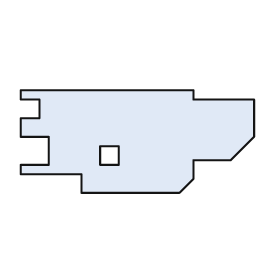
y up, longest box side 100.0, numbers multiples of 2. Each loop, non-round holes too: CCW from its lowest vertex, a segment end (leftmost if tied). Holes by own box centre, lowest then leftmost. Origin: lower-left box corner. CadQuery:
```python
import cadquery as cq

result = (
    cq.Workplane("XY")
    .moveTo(26.0, 0.0)
    .lineTo(68.0, 0.0)
    .lineTo(74.0, 6.0)
    .lineTo(74.0, 14.0)
    .lineTo(90.0, 14.0)
    .lineTo(100.0, 24.0)
    .lineTo(100.0, 40.0)
    .lineTo(74.0, 40.0)
    .lineTo(74.0, 44.0)
    .lineTo(0.0, 44.0)
    .lineTo(0.0, 40.0)
    .lineTo(8.0, 40.0)
    .lineTo(8.0, 32.0)
    .lineTo(0.0, 32.0)
    .lineTo(0.0, 24.0)
    .lineTo(12.0, 24.0)
    .lineTo(12.0, 12.0)
    .lineTo(0.0, 12.0)
    .lineTo(0.0, 8.0)
    .lineTo(26.0, 8.0)
    .close()
    .moveTo(34.0, 12.0)
    .lineTo(42.0, 12.0)
    .lineTo(42.0, 20.0)
    .lineTo(34.0, 20.0)
    .close()
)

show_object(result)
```